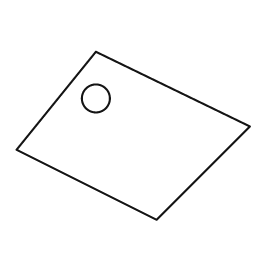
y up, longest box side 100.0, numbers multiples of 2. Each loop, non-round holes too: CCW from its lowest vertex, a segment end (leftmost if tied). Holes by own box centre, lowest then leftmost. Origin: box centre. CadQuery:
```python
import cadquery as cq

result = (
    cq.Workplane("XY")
    .moveTo(10.0, -36.0)
    .lineTo(50.0, 4.0)
    .lineTo(-16.0, 36.0)
    .lineTo(-50.0, -6.0)
    .close()
    .moveTo(-16.0, 16.0)
    .circle(6.0)
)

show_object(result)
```